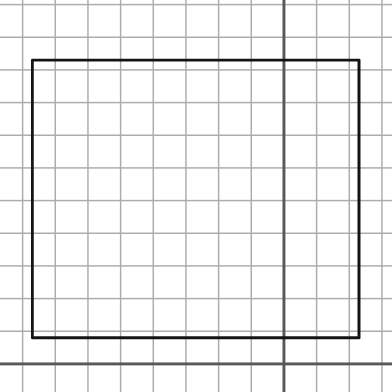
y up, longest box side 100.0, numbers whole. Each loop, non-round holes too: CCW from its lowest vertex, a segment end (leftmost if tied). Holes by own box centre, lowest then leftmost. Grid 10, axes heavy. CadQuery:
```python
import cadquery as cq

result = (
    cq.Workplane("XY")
    .moveTo(-77.0, 8.0)
    .lineTo(23.0, 8.0)
    .lineTo(23.0, 93.0)
    .lineTo(-77.0, 93.0)
    .close()
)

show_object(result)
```